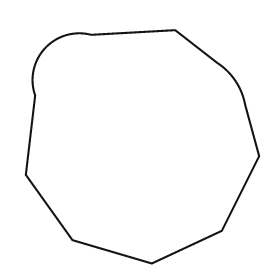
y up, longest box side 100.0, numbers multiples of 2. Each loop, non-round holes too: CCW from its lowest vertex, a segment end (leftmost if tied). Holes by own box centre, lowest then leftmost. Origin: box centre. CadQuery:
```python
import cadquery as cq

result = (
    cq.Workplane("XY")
    .moveTo(4.0, -50.0)
    .lineTo(34.0, -36.0)
    .lineTo(50.0, -4.0)
    .lineTo(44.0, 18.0)
    .threePointArc((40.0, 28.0), (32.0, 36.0))
    .lineTo(14.0, 50.0)
    .lineTo(-22.0, 48.0)
    .threePointArc((-42.0, 42.0), (-46.0, 22.0))
    .lineTo(-50.0, -12.0)
    .lineTo(-30.0, -40.0)
    .close()
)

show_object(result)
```